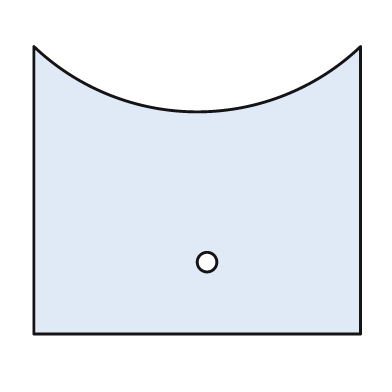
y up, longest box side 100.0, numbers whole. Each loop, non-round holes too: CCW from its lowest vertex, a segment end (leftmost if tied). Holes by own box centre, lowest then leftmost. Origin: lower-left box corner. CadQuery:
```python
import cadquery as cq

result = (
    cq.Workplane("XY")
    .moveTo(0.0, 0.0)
    .lineTo(100.0, 0.0)
    .lineTo(100.0, 88.0)
    .threePointArc((50.0, 68.0), (0.0, 88.0))
    .close()
    .moveTo(53.0, 22.0)
    .circle(3.0)
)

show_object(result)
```